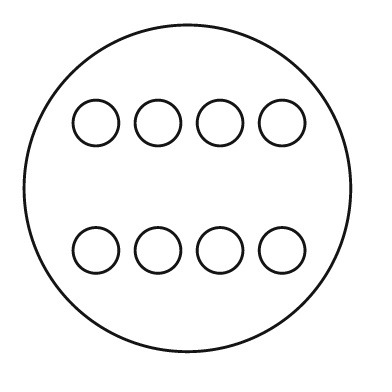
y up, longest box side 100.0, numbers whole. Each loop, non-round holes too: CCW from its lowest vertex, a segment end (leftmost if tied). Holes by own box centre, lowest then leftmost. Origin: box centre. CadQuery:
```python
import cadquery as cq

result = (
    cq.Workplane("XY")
    .moveTo(0.0, 0.0)
    .circle(50.0)
    .moveTo(-28.0, -19.0)
    .circle(7.0)
    .moveTo(-9.0, -19.0)
    .circle(7.0)
    .moveTo(10.0, -19.0)
    .circle(7.0)
    .moveTo(29.0, -19.0)
    .circle(7.0)
    .moveTo(-28.0, 20.0)
    .circle(7.0)
    .moveTo(-9.0, 20.0)
    .circle(7.0)
    .moveTo(10.0, 20.0)
    .circle(7.0)
    .moveTo(29.0, 20.0)
    .circle(7.0)
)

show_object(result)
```